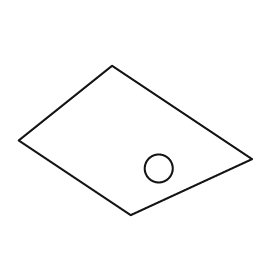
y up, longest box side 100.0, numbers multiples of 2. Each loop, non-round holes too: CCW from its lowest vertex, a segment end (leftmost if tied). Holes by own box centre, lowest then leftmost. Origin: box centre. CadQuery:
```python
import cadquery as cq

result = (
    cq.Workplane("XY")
    .moveTo(-2.0, -32.0)
    .lineTo(50.0, -8.0)
    .lineTo(-10.0, 32.0)
    .lineTo(-50.0, 0.0)
    .close()
    .moveTo(10.0, -12.0)
    .circle(6.0)
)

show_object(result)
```